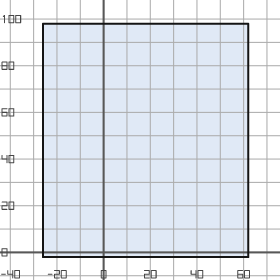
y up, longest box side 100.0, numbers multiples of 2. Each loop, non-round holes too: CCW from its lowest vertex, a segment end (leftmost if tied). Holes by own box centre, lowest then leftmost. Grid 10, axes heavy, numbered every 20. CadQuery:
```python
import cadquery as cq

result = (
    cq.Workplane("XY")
    .moveTo(-26.0, -2.0)
    .lineTo(62.0, -2.0)
    .lineTo(62.0, 98.0)
    .lineTo(-26.0, 98.0)
    .close()
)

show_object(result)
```